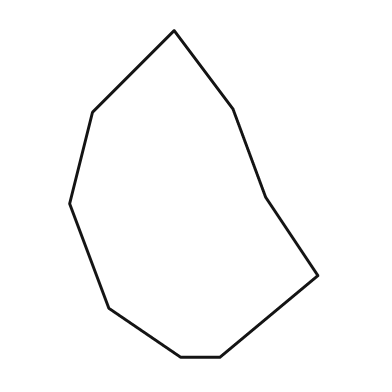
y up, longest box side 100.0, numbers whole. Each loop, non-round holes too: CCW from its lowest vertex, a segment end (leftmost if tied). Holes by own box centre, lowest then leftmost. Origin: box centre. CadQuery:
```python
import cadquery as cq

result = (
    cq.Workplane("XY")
    .moveTo(-4.0, -50.0)
    .lineTo(8.0, -50.0)
    .lineTo(38.0, -25.0)
    .lineTo(22.0, -1.0)
    .lineTo(12.0, 26.0)
    .lineTo(-6.0, 50.0)
    .lineTo(-31.0, 25.0)
    .lineTo(-38.0, -3.0)
    .lineTo(-26.0, -35.0)
    .close()
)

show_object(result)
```